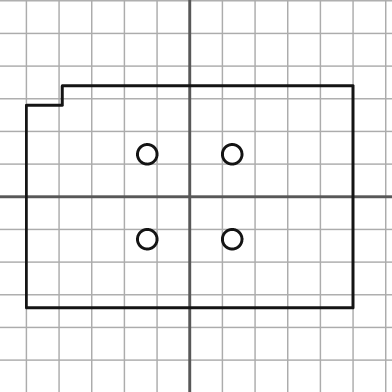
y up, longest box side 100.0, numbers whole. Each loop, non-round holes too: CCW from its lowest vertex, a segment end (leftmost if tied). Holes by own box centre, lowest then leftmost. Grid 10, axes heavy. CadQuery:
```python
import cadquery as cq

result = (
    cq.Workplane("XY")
    .moveTo(-50.0, -34.0)
    .lineTo(50.0, -34.0)
    .lineTo(50.0, 34.0)
    .lineTo(-39.0, 34.0)
    .lineTo(-39.0, 28.0)
    .lineTo(-50.0, 28.0)
    .close()
    .moveTo(-13.0, -13.0)
    .circle(3.0)
    .moveTo(13.0, -13.0)
    .circle(3.0)
    .moveTo(-13.0, 13.0)
    .circle(3.0)
    .moveTo(13.0, 13.0)
    .circle(3.0)
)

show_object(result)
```